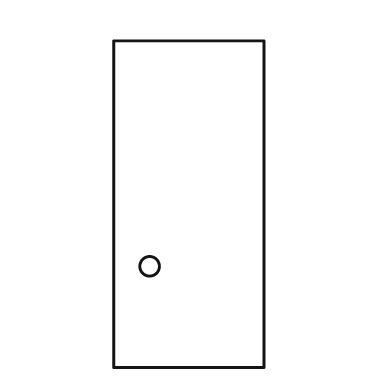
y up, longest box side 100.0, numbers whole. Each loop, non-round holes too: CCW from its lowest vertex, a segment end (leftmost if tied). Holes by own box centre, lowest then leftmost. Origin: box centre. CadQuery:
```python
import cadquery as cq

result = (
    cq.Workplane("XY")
    .moveTo(-23.0, -50.0)
    .lineTo(23.0, -50.0)
    .lineTo(23.0, 50.0)
    .lineTo(-23.0, 50.0)
    .close()
    .moveTo(-12.0, -19.0)
    .circle(3.0)
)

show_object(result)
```